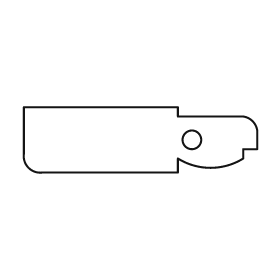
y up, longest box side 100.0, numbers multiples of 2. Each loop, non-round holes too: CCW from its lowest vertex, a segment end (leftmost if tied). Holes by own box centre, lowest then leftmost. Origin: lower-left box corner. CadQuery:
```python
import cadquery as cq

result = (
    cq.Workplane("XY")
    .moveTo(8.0, 0.0)
    .lineTo(66.0, 0.0)
    .lineTo(66.0, 6.0)
    .threePointArc((80.0, 2.0), (94.0, 6.0))
    .lineTo(94.0, 10.0)
    .lineTo(100.0, 10.0)
    .lineTo(100.0, 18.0)
    .threePointArc((98.0, 22.0), (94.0, 24.0))
    .lineTo(66.0, 24.0)
    .lineTo(66.0, 28.0)
    .lineTo(0.0, 28.0)
    .lineTo(0.0, 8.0)
    .threePointArc((2.0, 2.0), (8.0, 0.0))
    .close()
    .moveTo(72.0, 14.0)
    .circle(4.0)
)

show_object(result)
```